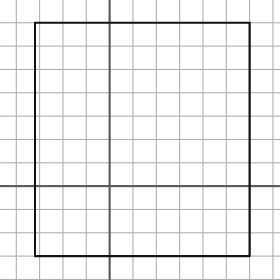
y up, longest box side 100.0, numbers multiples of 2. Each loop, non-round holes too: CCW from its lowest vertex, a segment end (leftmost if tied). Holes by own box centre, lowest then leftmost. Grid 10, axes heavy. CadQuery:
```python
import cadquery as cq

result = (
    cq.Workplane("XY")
    .moveTo(-32.0, -30.0)
    .lineTo(60.0, -30.0)
    .lineTo(60.0, 70.0)
    .lineTo(-32.0, 70.0)
    .close()
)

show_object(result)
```